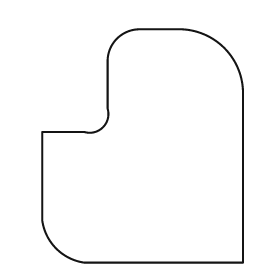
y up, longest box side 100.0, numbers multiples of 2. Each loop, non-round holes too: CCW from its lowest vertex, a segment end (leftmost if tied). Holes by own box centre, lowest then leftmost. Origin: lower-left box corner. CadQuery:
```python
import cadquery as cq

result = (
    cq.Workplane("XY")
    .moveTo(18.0, 0.0)
    .lineTo(86.0, 0.0)
    .lineTo(86.0, 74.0)
    .threePointArc((78.0, 92.0), (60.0, 100.0))
    .lineTo(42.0, 100.0)
    .threePointArc((32.0, 96.0), (28.0, 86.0))
    .lineTo(28.0, 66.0)
    .threePointArc((26.0, 58.0), (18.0, 56.0))
    .lineTo(0.0, 56.0)
    .lineTo(0.0, 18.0)
    .threePointArc((6.0, 6.0), (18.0, 0.0))
    .close()
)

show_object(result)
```